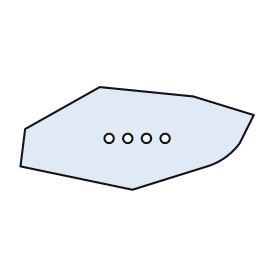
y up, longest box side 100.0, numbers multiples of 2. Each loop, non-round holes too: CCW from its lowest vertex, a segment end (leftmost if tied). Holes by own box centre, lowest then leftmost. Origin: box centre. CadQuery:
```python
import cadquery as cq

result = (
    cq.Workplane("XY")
    .moveTo(-2.0, -22.0)
    .lineTo(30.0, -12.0)
    .threePointArc((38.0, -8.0), (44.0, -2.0))
    .lineTo(50.0, 10.0)
    .lineTo(24.0, 18.0)
    .lineTo(-16.0, 22.0)
    .lineTo(-48.0, 4.0)
    .lineTo(-50.0, -12.0)
    .close()
    .moveTo(-12.0, 0.0)
    .circle(2.0)
    .moveTo(-4.0, 0.0)
    .circle(2.0)
    .moveTo(4.0, 0.0)
    .circle(2.0)
    .moveTo(12.0, 0.0)
    .circle(2.0)
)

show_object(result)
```